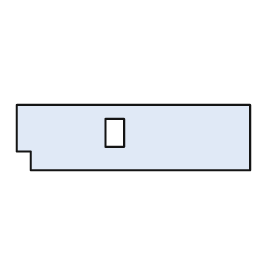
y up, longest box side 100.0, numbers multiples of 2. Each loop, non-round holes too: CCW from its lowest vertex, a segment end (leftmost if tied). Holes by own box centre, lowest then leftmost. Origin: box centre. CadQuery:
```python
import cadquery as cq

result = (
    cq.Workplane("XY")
    .moveTo(-44.0, -14.0)
    .lineTo(50.0, -14.0)
    .lineTo(50.0, 14.0)
    .lineTo(-50.0, 14.0)
    .lineTo(-50.0, -6.0)
    .lineTo(-44.0, -6.0)
    .close()
    .moveTo(-12.0, -4.0)
    .lineTo(-4.0, -4.0)
    .lineTo(-4.0, 8.0)
    .lineTo(-12.0, 8.0)
    .close()
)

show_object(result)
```